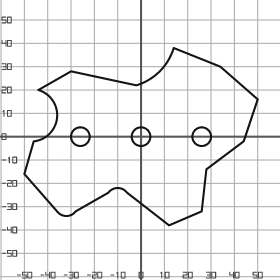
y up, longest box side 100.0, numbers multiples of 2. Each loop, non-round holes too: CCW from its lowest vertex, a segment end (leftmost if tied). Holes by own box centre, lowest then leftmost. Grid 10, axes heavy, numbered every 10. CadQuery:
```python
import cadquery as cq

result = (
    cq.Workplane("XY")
    .moveTo(12.0, -38.0)
    .lineTo(26.0, -32.0)
    .lineTo(28.0, -14.0)
    .lineTo(44.0, -2.0)
    .lineTo(50.0, 16.0)
    .lineTo(34.0, 30.0)
    .lineTo(14.0, 38.0)
    .threePointArc((8.0, 28.0), (-2.0, 22.0))
    .lineTo(-30.0, 28.0)
    .lineTo(-44.0, 20.0)
    .threePointArc((-36.0, 8.0), (-46.0, -2.0))
    .lineTo(-50.0, -16.0)
    .lineTo(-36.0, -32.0)
    .threePointArc((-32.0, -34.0), (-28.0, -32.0))
    .lineTo(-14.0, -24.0)
    .threePointArc((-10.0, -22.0), (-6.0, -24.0))
    .close()
    .moveTo(-26.0, 0.0)
    .circle(4.0)
    .moveTo(0.0, 0.0)
    .circle(4.0)
    .moveTo(26.0, 0.0)
    .circle(4.0)
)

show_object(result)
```